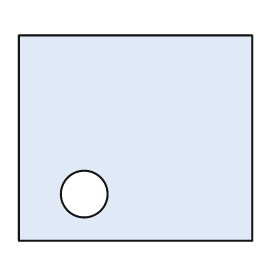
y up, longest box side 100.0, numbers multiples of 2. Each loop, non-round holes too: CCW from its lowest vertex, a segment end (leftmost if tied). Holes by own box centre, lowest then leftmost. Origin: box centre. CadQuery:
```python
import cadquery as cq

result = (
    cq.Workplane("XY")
    .moveTo(-50.0, -44.0)
    .lineTo(50.0, -44.0)
    .lineTo(50.0, 44.0)
    .lineTo(-50.0, 44.0)
    .close()
    .moveTo(-22.0, -24.0)
    .circle(10.0)
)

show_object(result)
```